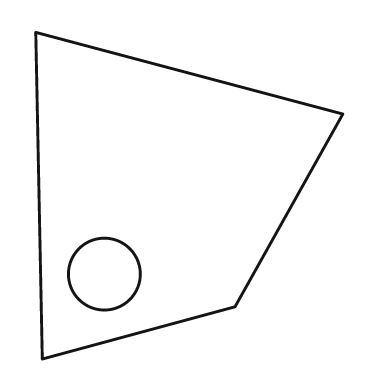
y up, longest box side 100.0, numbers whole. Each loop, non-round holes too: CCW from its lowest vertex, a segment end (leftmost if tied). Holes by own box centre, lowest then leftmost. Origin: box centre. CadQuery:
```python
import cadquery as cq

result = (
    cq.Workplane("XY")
    .moveTo(-45.0, -50.0)
    .lineTo(14.0, -34.0)
    .lineTo(47.0, 25.0)
    .lineTo(-47.0, 50.0)
    .close()
    .moveTo(-26.0, -24.0)
    .circle(11.0)
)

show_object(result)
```